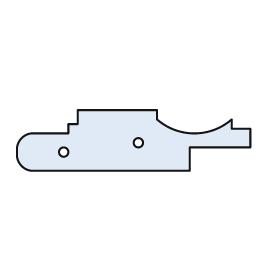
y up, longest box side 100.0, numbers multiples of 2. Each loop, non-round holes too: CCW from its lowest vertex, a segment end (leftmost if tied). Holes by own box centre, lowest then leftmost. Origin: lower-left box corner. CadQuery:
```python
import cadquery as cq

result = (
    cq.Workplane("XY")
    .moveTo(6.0, 0.0)
    .lineTo(74.0, 0.0)
    .lineTo(74.0, 10.0)
    .lineTo(100.0, 10.0)
    .lineTo(100.0, 18.0)
    .lineTo(92.0, 18.0)
    .lineTo(92.0, 22.0)
    .threePointArc((76.0, 16.0), (60.0, 22.0))
    .lineTo(60.0, 26.0)
    .lineTo(26.0, 26.0)
    .lineTo(26.0, 20.0)
    .lineTo(22.0, 20.0)
    .lineTo(22.0, 16.0)
    .lineTo(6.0, 16.0)
    .threePointArc((2.0, 14.0), (0.0, 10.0))
    .lineTo(0.0, 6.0)
    .threePointArc((2.0, 2.0), (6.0, 0.0))
    .close()
    .moveTo(20.0, 8.0)
    .circle(2.0)
    .moveTo(52.0, 12.0)
    .circle(2.0)
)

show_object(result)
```